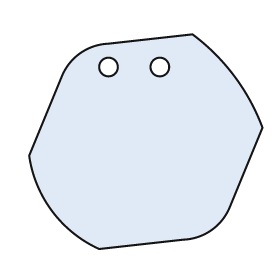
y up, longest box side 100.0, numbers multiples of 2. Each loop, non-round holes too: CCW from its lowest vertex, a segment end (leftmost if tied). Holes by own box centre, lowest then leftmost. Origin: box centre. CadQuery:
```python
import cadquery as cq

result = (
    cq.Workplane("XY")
    .moveTo(-20.0, -46.0)
    .lineTo(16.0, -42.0)
    .threePointArc((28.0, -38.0), (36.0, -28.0))
    .lineTo(50.0, 6.0)
    .threePointArc((38.0, 28.0), (20.0, 46.0))
    .lineTo(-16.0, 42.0)
    .threePointArc((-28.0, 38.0), (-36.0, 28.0))
    .lineTo(-50.0, -6.0)
    .threePointArc((-40.0, -30.0), (-20.0, -46.0))
    .close()
    .moveTo(-16.0, 32.0)
    .circle(4.0)
    .moveTo(6.0, 32.0)
    .circle(4.0)
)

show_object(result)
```